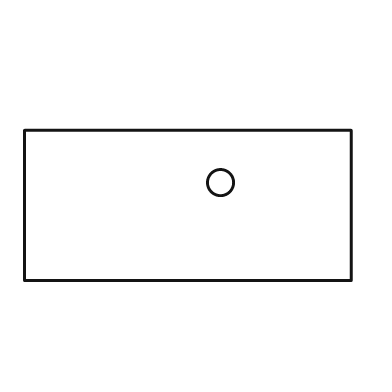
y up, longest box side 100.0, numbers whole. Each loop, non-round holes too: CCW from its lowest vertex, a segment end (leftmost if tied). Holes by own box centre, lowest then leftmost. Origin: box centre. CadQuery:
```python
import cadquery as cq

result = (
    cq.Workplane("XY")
    .moveTo(-50.0, -23.0)
    .lineTo(50.0, -23.0)
    .lineTo(50.0, 23.0)
    .lineTo(-50.0, 23.0)
    .close()
    .moveTo(10.0, 7.0)
    .circle(4.0)
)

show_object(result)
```